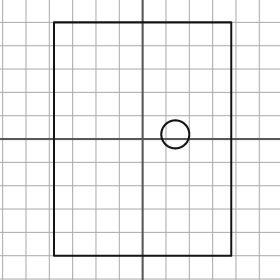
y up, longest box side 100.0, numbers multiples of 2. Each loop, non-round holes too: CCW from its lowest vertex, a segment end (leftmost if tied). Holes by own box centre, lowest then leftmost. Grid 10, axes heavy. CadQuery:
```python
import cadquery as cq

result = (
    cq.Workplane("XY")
    .moveTo(-38.0, -50.0)
    .lineTo(38.0, -50.0)
    .lineTo(38.0, 50.0)
    .lineTo(-38.0, 50.0)
    .close()
    .moveTo(14.0, 2.0)
    .circle(6.0)
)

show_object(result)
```